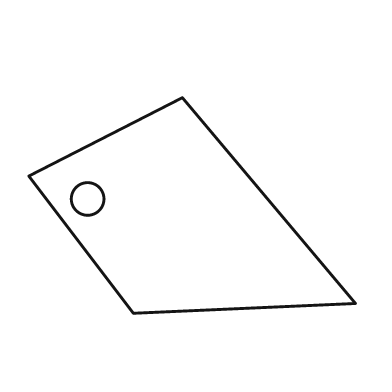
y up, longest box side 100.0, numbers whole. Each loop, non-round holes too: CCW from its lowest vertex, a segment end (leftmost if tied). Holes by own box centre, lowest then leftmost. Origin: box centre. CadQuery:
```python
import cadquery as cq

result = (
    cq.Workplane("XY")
    .moveTo(-18.0, -33.0)
    .lineTo(50.0, -30.0)
    .lineTo(-3.0, 33.0)
    .lineTo(-50.0, 9.0)
    .close()
    .moveTo(-32.0, 2.0)
    .circle(5.0)
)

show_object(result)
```